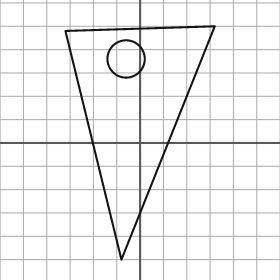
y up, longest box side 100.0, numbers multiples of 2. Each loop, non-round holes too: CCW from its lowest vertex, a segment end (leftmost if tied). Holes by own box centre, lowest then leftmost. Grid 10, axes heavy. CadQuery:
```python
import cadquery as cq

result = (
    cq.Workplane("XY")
    .moveTo(-8.0, -50.0)
    .lineTo(32.0, 50.0)
    .lineTo(-32.0, 48.0)
    .close()
    .moveTo(-6.0, 36.0)
    .circle(8.0)
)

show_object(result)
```